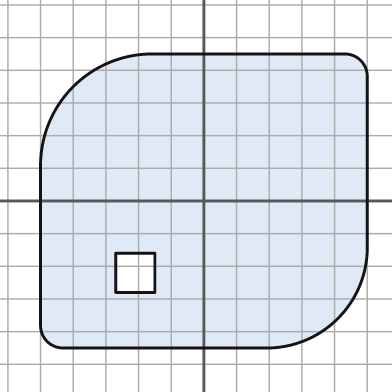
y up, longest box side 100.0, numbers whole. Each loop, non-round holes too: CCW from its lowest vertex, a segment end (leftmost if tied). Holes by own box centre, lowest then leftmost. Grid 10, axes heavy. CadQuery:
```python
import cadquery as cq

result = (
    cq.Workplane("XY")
    .moveTo(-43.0, -45.0)
    .lineTo(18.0, -45.0)
    .threePointArc((41.0, -36.0), (50.0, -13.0))
    .lineTo(50.0, 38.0)
    .threePointArc((48.0, 43.0), (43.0, 45.0))
    .lineTo(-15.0, 45.0)
    .threePointArc((-40.0, 35.0), (-50.0, 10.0))
    .lineTo(-50.0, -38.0)
    .threePointArc((-48.0, -43.0), (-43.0, -45.0))
    .close()
    .moveTo(-27.0, -28.0)
    .lineTo(-15.0, -28.0)
    .lineTo(-15.0, -16.0)
    .lineTo(-27.0, -16.0)
    .close()
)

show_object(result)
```